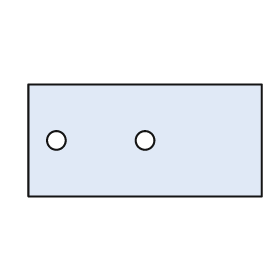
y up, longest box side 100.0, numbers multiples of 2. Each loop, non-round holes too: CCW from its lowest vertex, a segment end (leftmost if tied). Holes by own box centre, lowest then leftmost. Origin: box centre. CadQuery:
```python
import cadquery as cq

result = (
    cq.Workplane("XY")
    .moveTo(-50.0, -24.0)
    .lineTo(50.0, -24.0)
    .lineTo(50.0, 24.0)
    .lineTo(-50.0, 24.0)
    .close()
    .moveTo(-38.0, 0.0)
    .circle(4.0)
    .moveTo(0.0, 0.0)
    .circle(4.0)
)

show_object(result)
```